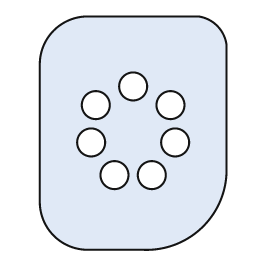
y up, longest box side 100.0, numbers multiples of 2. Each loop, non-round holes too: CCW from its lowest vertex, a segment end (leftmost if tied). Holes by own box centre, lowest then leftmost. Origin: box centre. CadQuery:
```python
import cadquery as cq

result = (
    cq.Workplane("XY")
    .moveTo(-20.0, -50.0)
    .lineTo(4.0, -50.0)
    .threePointArc((30.0, -40.0), (40.0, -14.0))
    .lineTo(40.0, 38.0)
    .threePointArc((36.0, 46.0), (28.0, 50.0))
    .lineTo(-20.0, 50.0)
    .threePointArc((-34.0, 44.0), (-40.0, 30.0))
    .lineTo(-40.0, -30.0)
    .threePointArc((-34.0, -44.0), (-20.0, -50.0))
    .close()
    .moveTo(-8.0, -18.0)
    .circle(6.0)
    .moveTo(8.0, -18.0)
    .circle(6.0)
    .moveTo(-18.0, -4.0)
    .circle(6.0)
    .moveTo(18.0, -4.0)
    .circle(6.0)
    .moveTo(-16.0, 12.0)
    .circle(6.0)
    .moveTo(16.0, 12.0)
    .circle(6.0)
    .moveTo(0.0, 20.0)
    .circle(6.0)
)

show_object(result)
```